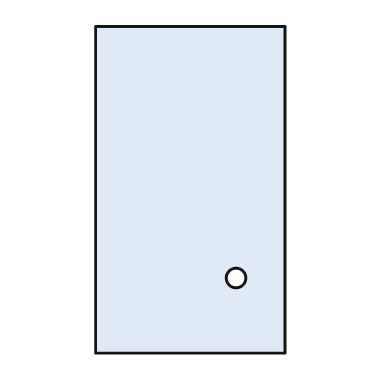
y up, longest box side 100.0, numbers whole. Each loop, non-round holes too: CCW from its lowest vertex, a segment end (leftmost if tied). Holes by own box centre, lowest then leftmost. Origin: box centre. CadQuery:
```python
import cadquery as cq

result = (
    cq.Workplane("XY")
    .moveTo(-29.0, -50.0)
    .lineTo(29.0, -50.0)
    .lineTo(29.0, 50.0)
    .lineTo(-29.0, 50.0)
    .close()
    .moveTo(14.0, -27.0)
    .circle(3.0)
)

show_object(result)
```